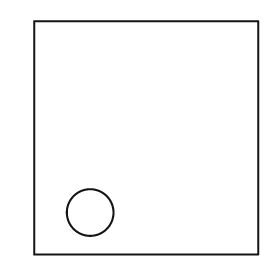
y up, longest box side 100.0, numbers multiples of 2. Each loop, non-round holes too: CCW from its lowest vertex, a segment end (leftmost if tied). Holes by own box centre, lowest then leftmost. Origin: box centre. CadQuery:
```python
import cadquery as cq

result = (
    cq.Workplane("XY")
    .moveTo(-48.0, -50.0)
    .lineTo(48.0, -50.0)
    .lineTo(48.0, 50.0)
    .lineTo(-48.0, 50.0)
    .close()
    .moveTo(-24.0, -32.0)
    .circle(10.0)
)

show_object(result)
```